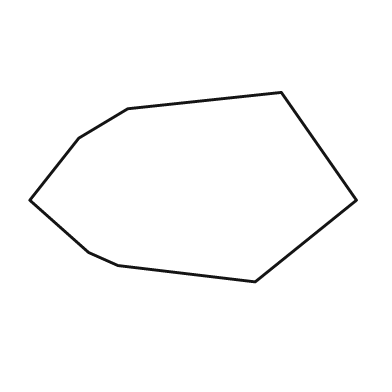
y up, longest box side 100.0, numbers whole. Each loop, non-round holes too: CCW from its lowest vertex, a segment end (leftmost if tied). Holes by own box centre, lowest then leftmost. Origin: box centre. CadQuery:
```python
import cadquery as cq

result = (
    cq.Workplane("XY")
    .moveTo(19.0, -29.0)
    .lineTo(50.0, -4.0)
    .lineTo(27.0, 29.0)
    .lineTo(-20.0, 24.0)
    .lineTo(-35.0, 15.0)
    .lineTo(-50.0, -4.0)
    .lineTo(-32.0, -20.0)
    .lineTo(-23.0, -24.0)
    .close()
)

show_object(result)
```